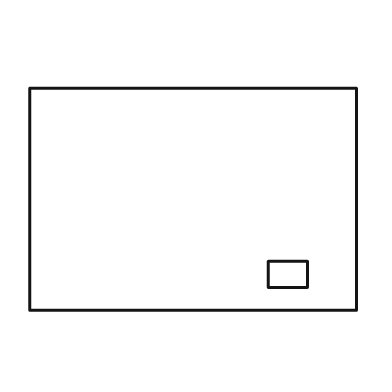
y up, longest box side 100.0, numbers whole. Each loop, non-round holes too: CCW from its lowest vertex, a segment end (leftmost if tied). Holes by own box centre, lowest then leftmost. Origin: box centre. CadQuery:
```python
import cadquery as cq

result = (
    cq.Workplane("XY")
    .moveTo(-50.0, -34.0)
    .lineTo(50.0, -34.0)
    .lineTo(50.0, 34.0)
    .lineTo(-50.0, 34.0)
    .close()
    .moveTo(23.0, -27.0)
    .lineTo(35.0, -27.0)
    .lineTo(35.0, -19.0)
    .lineTo(23.0, -19.0)
    .close()
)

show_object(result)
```